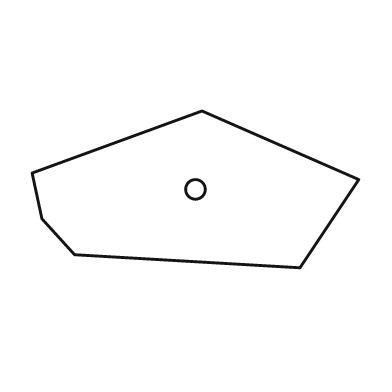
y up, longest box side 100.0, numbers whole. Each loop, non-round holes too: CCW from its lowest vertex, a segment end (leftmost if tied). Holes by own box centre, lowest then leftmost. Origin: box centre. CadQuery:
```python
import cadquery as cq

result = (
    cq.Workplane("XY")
    .moveTo(32.0, -24.0)
    .lineTo(50.0, 3.0)
    .lineTo(2.0, 24.0)
    .lineTo(-50.0, 5.0)
    .lineTo(-47.0, -9.0)
    .lineTo(-37.0, -20.0)
    .close()
    .moveTo(0.0, 0.0)
    .circle(3.0)
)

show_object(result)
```